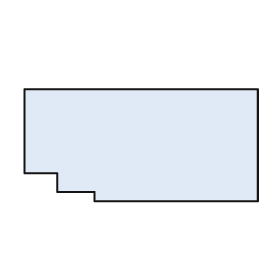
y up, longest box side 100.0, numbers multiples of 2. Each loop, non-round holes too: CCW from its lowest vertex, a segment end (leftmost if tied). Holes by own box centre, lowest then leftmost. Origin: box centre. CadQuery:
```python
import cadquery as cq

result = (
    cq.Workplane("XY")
    .moveTo(-20.0, -24.0)
    .lineTo(50.0, -24.0)
    .lineTo(50.0, 24.0)
    .lineTo(-50.0, 24.0)
    .lineTo(-50.0, -12.0)
    .lineTo(-36.0, -12.0)
    .lineTo(-36.0, -20.0)
    .lineTo(-20.0, -20.0)
    .close()
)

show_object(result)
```